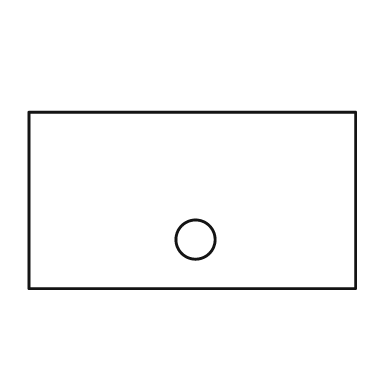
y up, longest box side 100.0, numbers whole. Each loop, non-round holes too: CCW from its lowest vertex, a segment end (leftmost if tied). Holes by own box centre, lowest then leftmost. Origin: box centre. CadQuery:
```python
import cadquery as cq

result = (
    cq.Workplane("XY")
    .moveTo(-50.0, -27.0)
    .lineTo(50.0, -27.0)
    .lineTo(50.0, 27.0)
    .lineTo(-50.0, 27.0)
    .close()
    .moveTo(1.0, -12.0)
    .circle(6.0)
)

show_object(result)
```